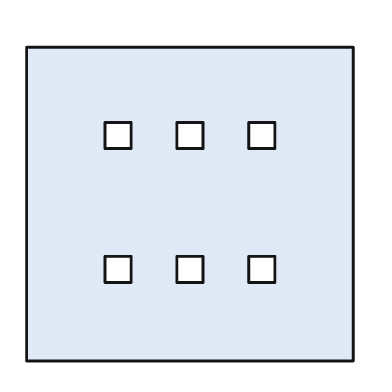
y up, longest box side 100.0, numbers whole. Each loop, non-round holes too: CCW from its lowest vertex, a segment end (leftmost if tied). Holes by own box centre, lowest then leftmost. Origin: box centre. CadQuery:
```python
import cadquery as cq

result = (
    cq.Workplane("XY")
    .moveTo(-50.0, -48.0)
    .lineTo(50.0, -48.0)
    .lineTo(50.0, 48.0)
    .lineTo(-50.0, 48.0)
    .close()
    .moveTo(-26.0, -24.0)
    .lineTo(-18.0, -24.0)
    .lineTo(-18.0, -16.0)
    .lineTo(-26.0, -16.0)
    .close()
    .moveTo(-4.0, -24.0)
    .lineTo(4.0, -24.0)
    .lineTo(4.0, -16.0)
    .lineTo(-4.0, -16.0)
    .close()
    .moveTo(18.0, -24.0)
    .lineTo(26.0, -24.0)
    .lineTo(26.0, -16.0)
    .lineTo(18.0, -16.0)
    .close()
    .moveTo(-26.0, 17.0)
    .lineTo(-18.0, 17.0)
    .lineTo(-18.0, 25.0)
    .lineTo(-26.0, 25.0)
    .close()
    .moveTo(-4.0, 17.0)
    .lineTo(4.0, 17.0)
    .lineTo(4.0, 25.0)
    .lineTo(-4.0, 25.0)
    .close()
    .moveTo(18.0, 17.0)
    .lineTo(26.0, 17.0)
    .lineTo(26.0, 25.0)
    .lineTo(18.0, 25.0)
    .close()
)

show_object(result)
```